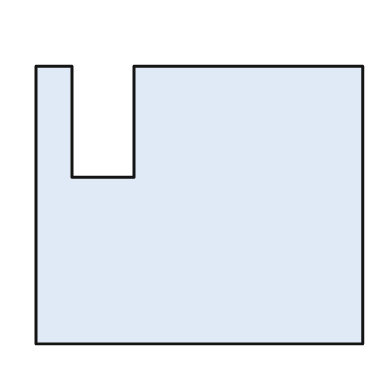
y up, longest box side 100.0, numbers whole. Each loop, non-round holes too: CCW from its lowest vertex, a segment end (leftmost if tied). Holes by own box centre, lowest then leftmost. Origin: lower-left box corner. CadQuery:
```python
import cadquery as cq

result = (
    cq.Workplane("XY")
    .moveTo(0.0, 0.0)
    .lineTo(100.0, 0.0)
    .lineTo(100.0, 85.0)
    .lineTo(30.0, 85.0)
    .lineTo(30.0, 51.0)
    .lineTo(11.0, 51.0)
    .lineTo(11.0, 85.0)
    .lineTo(0.0, 85.0)
    .close()
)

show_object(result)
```